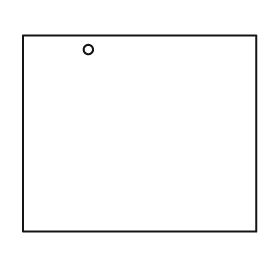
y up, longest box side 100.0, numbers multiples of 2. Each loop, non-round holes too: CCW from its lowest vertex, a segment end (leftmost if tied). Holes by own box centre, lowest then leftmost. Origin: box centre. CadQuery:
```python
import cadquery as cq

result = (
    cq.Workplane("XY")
    .moveTo(-50.0, -42.0)
    .lineTo(50.0, -42.0)
    .lineTo(50.0, 42.0)
    .lineTo(-50.0, 42.0)
    .close()
    .moveTo(-22.0, 36.0)
    .circle(2.0)
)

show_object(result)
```